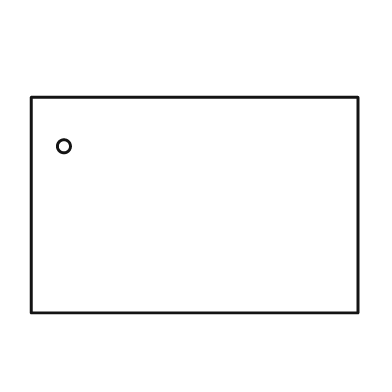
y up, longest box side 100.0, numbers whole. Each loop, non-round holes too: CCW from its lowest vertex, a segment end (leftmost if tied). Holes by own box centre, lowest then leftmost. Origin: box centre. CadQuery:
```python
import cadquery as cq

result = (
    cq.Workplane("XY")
    .moveTo(-50.0, -33.0)
    .lineTo(50.0, -33.0)
    .lineTo(50.0, 33.0)
    .lineTo(-50.0, 33.0)
    .close()
    .moveTo(-40.0, 18.0)
    .circle(2.0)
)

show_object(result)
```